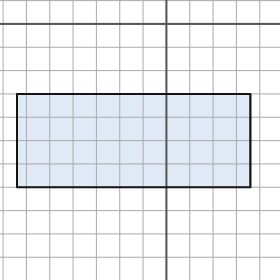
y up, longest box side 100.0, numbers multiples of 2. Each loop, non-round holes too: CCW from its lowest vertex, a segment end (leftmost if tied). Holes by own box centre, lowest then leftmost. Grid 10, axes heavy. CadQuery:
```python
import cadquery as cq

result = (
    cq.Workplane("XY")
    .moveTo(-64.0, -70.0)
    .lineTo(36.0, -70.0)
    .lineTo(36.0, -30.0)
    .lineTo(-64.0, -30.0)
    .close()
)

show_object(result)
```